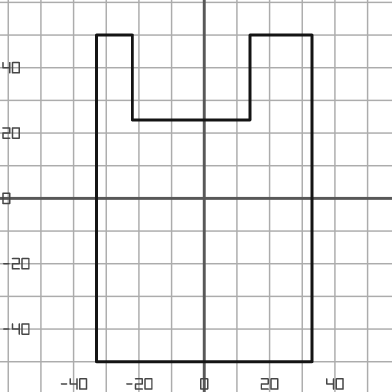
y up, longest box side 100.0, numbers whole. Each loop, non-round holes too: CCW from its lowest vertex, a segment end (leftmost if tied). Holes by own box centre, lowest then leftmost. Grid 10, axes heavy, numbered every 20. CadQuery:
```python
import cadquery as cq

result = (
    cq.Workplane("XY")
    .moveTo(-33.0, -50.0)
    .lineTo(33.0, -50.0)
    .lineTo(33.0, 50.0)
    .lineTo(14.0, 50.0)
    .lineTo(14.0, 24.0)
    .lineTo(-22.0, 24.0)
    .lineTo(-22.0, 50.0)
    .lineTo(-33.0, 50.0)
    .close()
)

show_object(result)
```